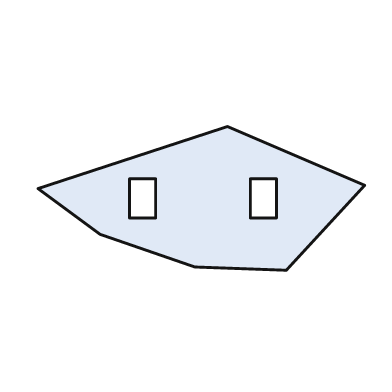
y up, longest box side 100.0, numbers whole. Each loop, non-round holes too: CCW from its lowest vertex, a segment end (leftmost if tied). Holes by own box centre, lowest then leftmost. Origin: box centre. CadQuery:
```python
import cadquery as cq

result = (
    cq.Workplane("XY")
    .moveTo(26.0, -22.0)
    .lineTo(50.0, 4.0)
    .lineTo(8.0, 22.0)
    .lineTo(-50.0, 3.0)
    .lineTo(-31.0, -11.0)
    .lineTo(-2.0, -21.0)
    .close()
    .moveTo(-22.0, -6.0)
    .lineTo(-14.0, -6.0)
    .lineTo(-14.0, 6.0)
    .lineTo(-22.0, 6.0)
    .close()
    .moveTo(15.0, -6.0)
    .lineTo(23.0, -6.0)
    .lineTo(23.0, 6.0)
    .lineTo(15.0, 6.0)
    .close()
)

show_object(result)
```